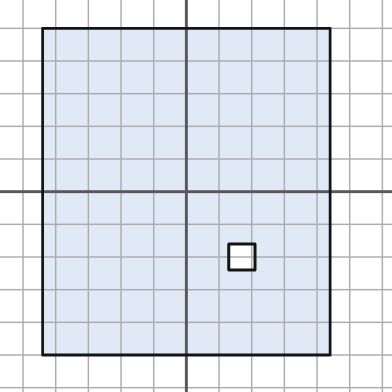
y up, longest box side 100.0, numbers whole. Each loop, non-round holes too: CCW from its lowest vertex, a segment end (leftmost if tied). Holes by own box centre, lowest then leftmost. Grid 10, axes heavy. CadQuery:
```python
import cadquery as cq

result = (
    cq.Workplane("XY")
    .moveTo(-44.0, -50.0)
    .lineTo(44.0, -50.0)
    .lineTo(44.0, 50.0)
    .lineTo(-44.0, 50.0)
    .close()
    .moveTo(13.0, -24.0)
    .lineTo(21.0, -24.0)
    .lineTo(21.0, -16.0)
    .lineTo(13.0, -16.0)
    .close()
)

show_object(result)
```